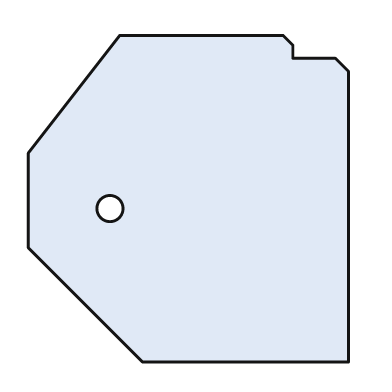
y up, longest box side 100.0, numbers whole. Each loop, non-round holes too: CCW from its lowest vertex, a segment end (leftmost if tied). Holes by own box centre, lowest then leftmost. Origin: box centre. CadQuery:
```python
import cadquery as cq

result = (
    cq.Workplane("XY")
    .moveTo(-14.0, -50.0)
    .lineTo(49.0, -50.0)
    .lineTo(49.0, 39.0)
    .lineTo(45.0, 43.0)
    .lineTo(32.0, 43.0)
    .lineTo(32.0, 47.0)
    .lineTo(29.0, 50.0)
    .lineTo(-21.0, 50.0)
    .lineTo(-49.0, 14.0)
    .lineTo(-49.0, -15.0)
    .close()
    .moveTo(-24.0, -3.0)
    .circle(4.0)
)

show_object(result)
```